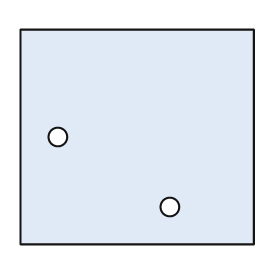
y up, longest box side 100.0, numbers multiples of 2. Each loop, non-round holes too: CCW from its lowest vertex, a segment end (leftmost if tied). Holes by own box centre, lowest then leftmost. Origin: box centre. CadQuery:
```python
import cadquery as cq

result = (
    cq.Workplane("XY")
    .moveTo(-50.0, -46.0)
    .lineTo(50.0, -46.0)
    .lineTo(50.0, 46.0)
    .lineTo(-50.0, 46.0)
    .close()
    .moveTo(14.0, -30.0)
    .circle(4.0)
    .moveTo(-34.0, 0.0)
    .circle(4.0)
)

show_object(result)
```